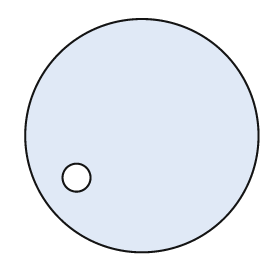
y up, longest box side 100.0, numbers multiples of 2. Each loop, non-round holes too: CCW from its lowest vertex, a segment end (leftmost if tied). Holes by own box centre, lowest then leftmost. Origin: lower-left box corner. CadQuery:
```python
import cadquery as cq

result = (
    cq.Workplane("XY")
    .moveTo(50.0, 50.0)
    .circle(50.0)
    .moveTo(22.0, 32.0)
    .circle(6.0)
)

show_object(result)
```